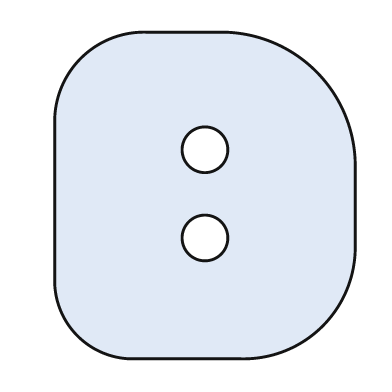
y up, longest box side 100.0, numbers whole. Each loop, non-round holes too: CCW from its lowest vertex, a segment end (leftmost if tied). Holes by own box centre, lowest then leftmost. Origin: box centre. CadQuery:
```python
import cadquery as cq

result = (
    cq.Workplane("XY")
    .moveTo(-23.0, -50.0)
    .lineTo(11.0, -50.0)
    .threePointArc((36.0, -40.0), (46.0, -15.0))
    .lineTo(46.0, 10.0)
    .threePointArc((34.0, 38.0), (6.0, 50.0))
    .lineTo(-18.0, 50.0)
    .threePointArc((-38.0, 42.0), (-46.0, 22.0))
    .lineTo(-46.0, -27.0)
    .threePointArc((-39.0, -43.0), (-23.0, -50.0))
    .close()
    .moveTo(0.0, -13.0)
    .circle(7.0)
    .moveTo(0.0, 14.0)
    .circle(7.0)
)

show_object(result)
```